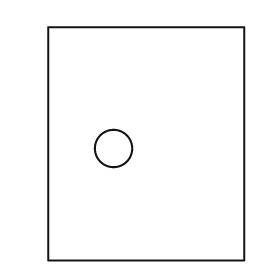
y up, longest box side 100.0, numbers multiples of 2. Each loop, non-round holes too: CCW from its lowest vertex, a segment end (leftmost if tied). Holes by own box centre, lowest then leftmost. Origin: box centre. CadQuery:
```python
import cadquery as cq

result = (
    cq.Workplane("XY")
    .moveTo(-42.0, -50.0)
    .lineTo(42.0, -50.0)
    .lineTo(42.0, 50.0)
    .lineTo(-42.0, 50.0)
    .close()
    .moveTo(-14.0, -2.0)
    .circle(8.0)
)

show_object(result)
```